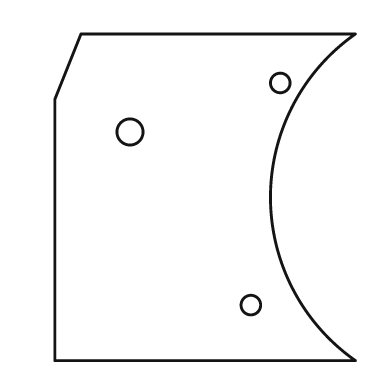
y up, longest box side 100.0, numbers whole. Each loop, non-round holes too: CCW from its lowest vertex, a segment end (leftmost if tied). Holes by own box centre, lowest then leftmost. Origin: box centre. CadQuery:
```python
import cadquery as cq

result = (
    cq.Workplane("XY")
    .moveTo(-46.0, -50.0)
    .lineTo(46.0, -50.0)
    .threePointArc((20.0, 0.0), (46.0, 50.0))
    .lineTo(-38.0, 50.0)
    .lineTo(-46.0, 30.0)
    .close()
    .moveTo(14.0, -33.0)
    .circle(3.0)
    .moveTo(-23.0, 20.0)
    .circle(4.0)
    .moveTo(23.0, 35.0)
    .circle(3.0)
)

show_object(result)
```